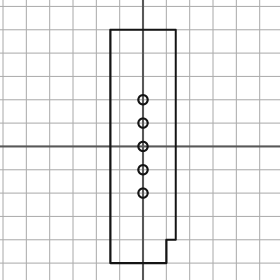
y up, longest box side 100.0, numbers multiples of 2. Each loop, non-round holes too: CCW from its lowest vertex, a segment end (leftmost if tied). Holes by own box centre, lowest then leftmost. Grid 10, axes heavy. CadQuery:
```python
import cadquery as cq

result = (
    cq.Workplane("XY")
    .moveTo(-14.0, -50.0)
    .lineTo(10.0, -50.0)
    .lineTo(10.0, -40.0)
    .lineTo(14.0, -40.0)
    .lineTo(14.0, 50.0)
    .lineTo(-14.0, 50.0)
    .close()
    .moveTo(0.0, -20.0)
    .circle(2.0)
    .moveTo(0.0, -10.0)
    .circle(2.0)
    .moveTo(0.0, 0.0)
    .circle(2.0)
    .moveTo(0.0, 10.0)
    .circle(2.0)
    .moveTo(0.0, 20.0)
    .circle(2.0)
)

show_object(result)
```